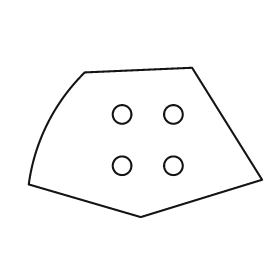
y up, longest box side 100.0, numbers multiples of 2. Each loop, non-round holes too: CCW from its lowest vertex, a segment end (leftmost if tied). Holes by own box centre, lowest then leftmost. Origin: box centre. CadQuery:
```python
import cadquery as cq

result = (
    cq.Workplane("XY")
    .moveTo(-2.0, -32.0)
    .lineTo(50.0, -16.0)
    .lineTo(20.0, 32.0)
    .lineTo(-26.0, 30.0)
    .threePointArc((-42.0, 8.0), (-50.0, -18.0))
    .close()
    .moveTo(-10.0, -10.0)
    .circle(4.0)
    .moveTo(12.0, -10.0)
    .circle(4.0)
    .moveTo(-10.0, 12.0)
    .circle(4.0)
    .moveTo(12.0, 12.0)
    .circle(4.0)
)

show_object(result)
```